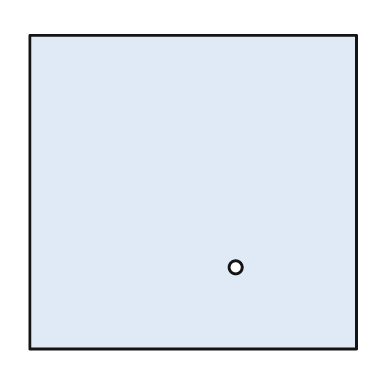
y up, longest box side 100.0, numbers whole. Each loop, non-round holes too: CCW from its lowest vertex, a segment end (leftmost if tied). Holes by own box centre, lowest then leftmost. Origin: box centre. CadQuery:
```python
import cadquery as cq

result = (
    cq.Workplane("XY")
    .moveTo(-50.0, -48.0)
    .lineTo(50.0, -48.0)
    .lineTo(50.0, 48.0)
    .lineTo(-50.0, 48.0)
    .close()
    .moveTo(13.0, -23.0)
    .circle(2.0)
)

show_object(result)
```